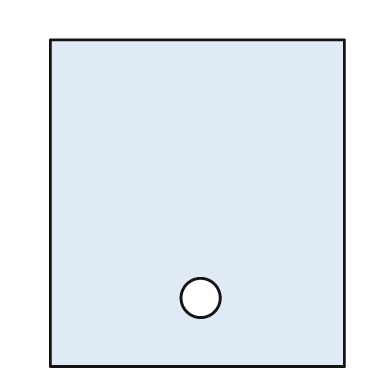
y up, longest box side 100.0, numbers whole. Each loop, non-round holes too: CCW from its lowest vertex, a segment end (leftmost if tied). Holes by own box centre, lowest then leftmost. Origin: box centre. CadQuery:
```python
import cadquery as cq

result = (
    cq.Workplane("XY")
    .moveTo(-45.0, -50.0)
    .lineTo(45.0, -50.0)
    .lineTo(45.0, 50.0)
    .lineTo(-45.0, 50.0)
    .close()
    .moveTo(1.0, -29.0)
    .circle(6.0)
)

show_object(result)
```